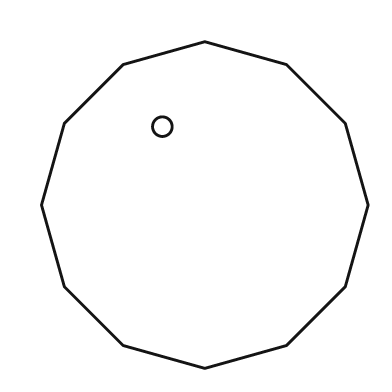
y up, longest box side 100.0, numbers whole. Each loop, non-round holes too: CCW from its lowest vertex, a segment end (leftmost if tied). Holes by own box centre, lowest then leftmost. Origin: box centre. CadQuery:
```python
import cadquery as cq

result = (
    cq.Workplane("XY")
    .moveTo(0.0, -50.0)
    .lineTo(25.0, -43.0)
    .lineTo(43.0, -25.0)
    .lineTo(50.0, 0.0)
    .lineTo(43.0, 25.0)
    .lineTo(25.0, 43.0)
    .lineTo(0.0, 50.0)
    .lineTo(-25.0, 43.0)
    .lineTo(-43.0, 25.0)
    .lineTo(-50.0, 0.0)
    .lineTo(-43.0, -25.0)
    .lineTo(-25.0, -43.0)
    .close()
    .moveTo(-13.0, 24.0)
    .circle(3.0)
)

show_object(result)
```